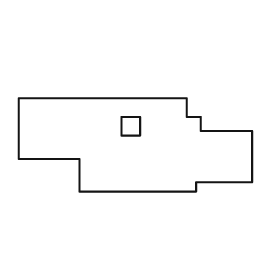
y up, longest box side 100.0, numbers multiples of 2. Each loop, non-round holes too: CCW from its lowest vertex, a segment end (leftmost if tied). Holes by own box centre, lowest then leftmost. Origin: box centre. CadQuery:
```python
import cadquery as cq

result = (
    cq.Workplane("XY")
    .moveTo(-24.0, -20.0)
    .lineTo(26.0, -20.0)
    .lineTo(26.0, -16.0)
    .lineTo(50.0, -16.0)
    .lineTo(50.0, 6.0)
    .lineTo(28.0, 6.0)
    .lineTo(28.0, 12.0)
    .lineTo(22.0, 12.0)
    .lineTo(22.0, 20.0)
    .lineTo(-50.0, 20.0)
    .lineTo(-50.0, -6.0)
    .lineTo(-24.0, -6.0)
    .close()
    .moveTo(-6.0, 4.0)
    .lineTo(2.0, 4.0)
    .lineTo(2.0, 12.0)
    .lineTo(-6.0, 12.0)
    .close()
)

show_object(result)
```